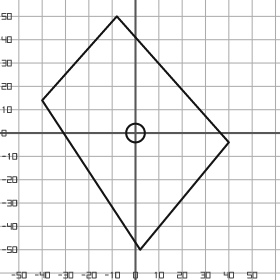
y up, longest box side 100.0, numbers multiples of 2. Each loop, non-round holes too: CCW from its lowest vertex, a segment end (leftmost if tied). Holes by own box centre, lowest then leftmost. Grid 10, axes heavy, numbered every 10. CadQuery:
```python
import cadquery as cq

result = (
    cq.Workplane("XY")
    .moveTo(2.0, -50.0)
    .lineTo(40.0, -4.0)
    .lineTo(-8.0, 50.0)
    .lineTo(-40.0, 14.0)
    .close()
    .moveTo(0.0, 0.0)
    .circle(4.0)
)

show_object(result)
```